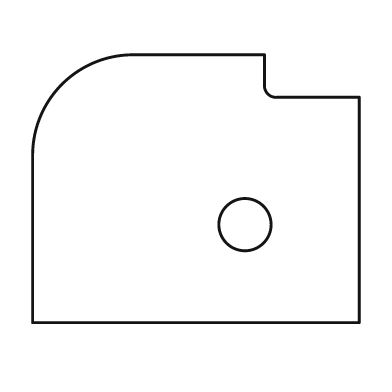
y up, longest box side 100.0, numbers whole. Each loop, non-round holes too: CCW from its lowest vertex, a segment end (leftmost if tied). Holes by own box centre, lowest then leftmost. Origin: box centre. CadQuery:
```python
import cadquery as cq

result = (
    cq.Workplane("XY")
    .moveTo(-50.0, -41.0)
    .lineTo(50.0, -41.0)
    .lineTo(50.0, 28.0)
    .lineTo(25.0, 28.0)
    .threePointArc((22.0, 29.0), (21.0, 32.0))
    .lineTo(21.0, 41.0)
    .lineTo(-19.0, 41.0)
    .threePointArc((-41.0, 32.0), (-50.0, 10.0))
    .close()
    .moveTo(15.0, -11.0)
    .circle(8.0)
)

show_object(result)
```